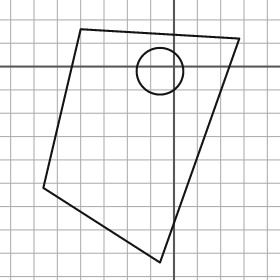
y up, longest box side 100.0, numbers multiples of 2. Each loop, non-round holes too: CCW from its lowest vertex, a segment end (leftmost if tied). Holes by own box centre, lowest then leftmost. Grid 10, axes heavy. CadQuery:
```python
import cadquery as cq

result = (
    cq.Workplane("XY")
    .moveTo(-6.0, -84.0)
    .lineTo(28.0, 12.0)
    .lineTo(-40.0, 16.0)
    .lineTo(-56.0, -52.0)
    .close()
    .moveTo(-6.0, -2.0)
    .circle(10.0)
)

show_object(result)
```